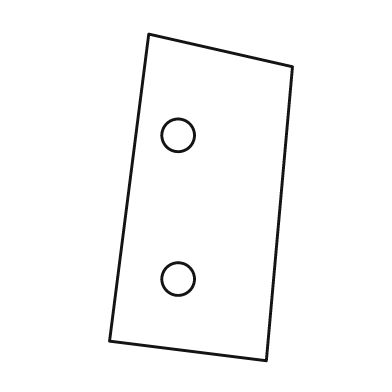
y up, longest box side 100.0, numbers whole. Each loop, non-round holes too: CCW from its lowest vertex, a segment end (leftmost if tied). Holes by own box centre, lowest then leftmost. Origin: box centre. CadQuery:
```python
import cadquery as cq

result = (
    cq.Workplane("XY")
    .moveTo(20.0, -50.0)
    .lineTo(28.0, 40.0)
    .lineTo(-16.0, 50.0)
    .lineTo(-28.0, -44.0)
    .close()
    .moveTo(-7.0, -25.0)
    .circle(5.0)
    .moveTo(-7.0, 19.0)
    .circle(5.0)
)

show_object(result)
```